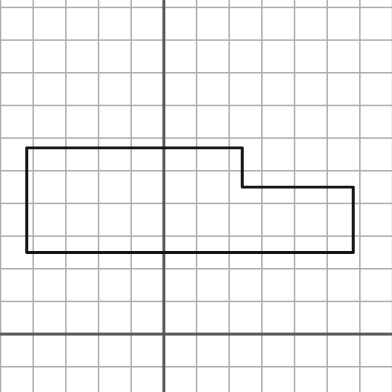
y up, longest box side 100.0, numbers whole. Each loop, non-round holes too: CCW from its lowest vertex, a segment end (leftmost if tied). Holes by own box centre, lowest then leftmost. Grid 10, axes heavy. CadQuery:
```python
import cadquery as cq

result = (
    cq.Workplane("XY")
    .moveTo(-42.0, 25.0)
    .lineTo(58.0, 25.0)
    .lineTo(58.0, 45.0)
    .lineTo(24.0, 45.0)
    .lineTo(24.0, 57.0)
    .lineTo(-42.0, 57.0)
    .close()
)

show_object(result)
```